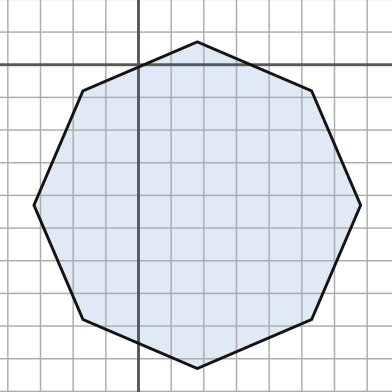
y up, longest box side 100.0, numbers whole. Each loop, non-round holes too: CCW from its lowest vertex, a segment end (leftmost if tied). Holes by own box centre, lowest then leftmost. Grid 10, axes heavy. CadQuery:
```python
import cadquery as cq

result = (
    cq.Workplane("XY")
    .moveTo(18.0, -93.0)
    .lineTo(53.0, -78.0)
    .lineTo(68.0, -43.0)
    .lineTo(53.0, -8.0)
    .lineTo(18.0, 7.0)
    .lineTo(-17.0, -8.0)
    .lineTo(-32.0, -43.0)
    .lineTo(-17.0, -78.0)
    .close()
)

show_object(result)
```